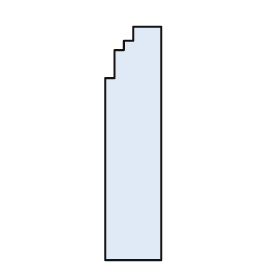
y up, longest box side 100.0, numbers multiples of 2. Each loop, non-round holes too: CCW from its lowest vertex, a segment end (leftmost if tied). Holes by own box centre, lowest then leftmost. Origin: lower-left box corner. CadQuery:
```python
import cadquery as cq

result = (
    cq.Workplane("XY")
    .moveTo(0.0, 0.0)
    .lineTo(24.0, 0.0)
    .lineTo(24.0, 100.0)
    .lineTo(12.0, 100.0)
    .lineTo(12.0, 94.0)
    .lineTo(8.0, 94.0)
    .lineTo(8.0, 90.0)
    .lineTo(4.0, 90.0)
    .lineTo(4.0, 78.0)
    .lineTo(0.0, 78.0)
    .close()
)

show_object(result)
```